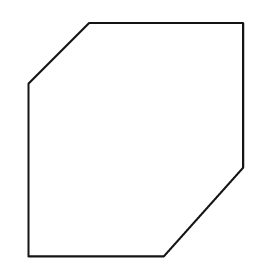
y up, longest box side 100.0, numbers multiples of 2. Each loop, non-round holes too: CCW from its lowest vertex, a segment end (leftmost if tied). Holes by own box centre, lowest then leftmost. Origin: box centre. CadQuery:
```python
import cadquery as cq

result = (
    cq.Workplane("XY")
    .moveTo(-46.0, -50.0)
    .lineTo(12.0, -50.0)
    .lineTo(46.0, -12.0)
    .lineTo(46.0, 50.0)
    .lineTo(-20.0, 50.0)
    .lineTo(-46.0, 24.0)
    .close()
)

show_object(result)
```